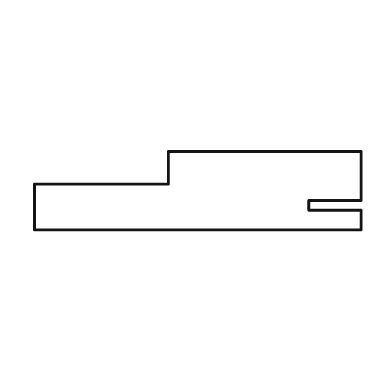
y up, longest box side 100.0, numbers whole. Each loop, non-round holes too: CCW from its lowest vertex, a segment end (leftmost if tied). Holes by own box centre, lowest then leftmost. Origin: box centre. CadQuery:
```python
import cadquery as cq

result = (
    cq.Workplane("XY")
    .moveTo(-50.0, -12.0)
    .lineTo(50.0, -12.0)
    .lineTo(50.0, -6.0)
    .lineTo(34.0, -6.0)
    .lineTo(34.0, -3.0)
    .lineTo(50.0, -3.0)
    .lineTo(50.0, 12.0)
    .lineTo(-9.0, 12.0)
    .lineTo(-9.0, 2.0)
    .lineTo(-50.0, 2.0)
    .close()
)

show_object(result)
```